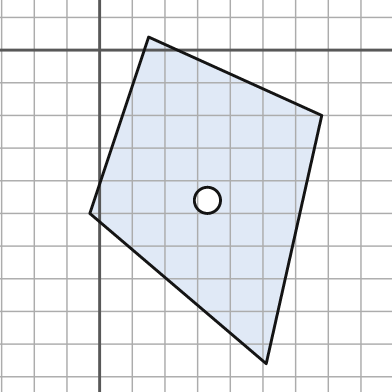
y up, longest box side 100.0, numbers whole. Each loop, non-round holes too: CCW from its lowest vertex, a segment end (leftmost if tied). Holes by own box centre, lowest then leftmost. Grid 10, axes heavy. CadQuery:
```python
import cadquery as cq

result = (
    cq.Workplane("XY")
    .moveTo(51.0, -96.0)
    .lineTo(68.0, -20.0)
    .lineTo(15.0, 4.0)
    .lineTo(-3.0, -50.0)
    .close()
    .moveTo(33.0, -46.0)
    .circle(4.0)
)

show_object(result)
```